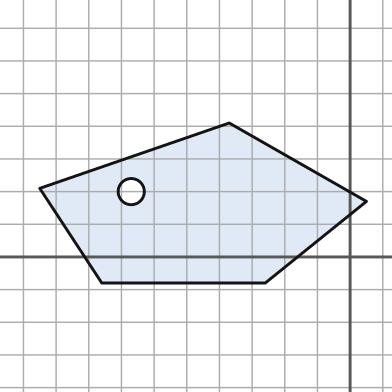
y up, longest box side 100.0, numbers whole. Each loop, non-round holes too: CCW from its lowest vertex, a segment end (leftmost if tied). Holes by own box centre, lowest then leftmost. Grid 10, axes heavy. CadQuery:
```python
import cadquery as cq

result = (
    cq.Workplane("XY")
    .moveTo(-76.0, -8.0)
    .lineTo(-26.0, -8.0)
    .lineTo(5.0, 17.0)
    .lineTo(-37.0, 41.0)
    .lineTo(-95.0, 21.0)
    .close()
    .moveTo(-67.0, 20.0)
    .circle(4.0)
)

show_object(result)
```